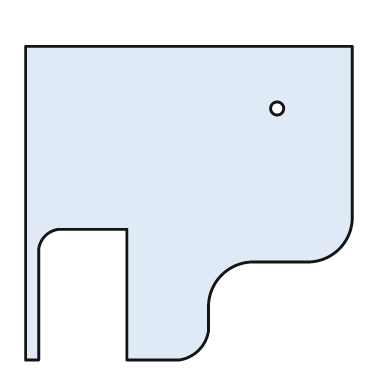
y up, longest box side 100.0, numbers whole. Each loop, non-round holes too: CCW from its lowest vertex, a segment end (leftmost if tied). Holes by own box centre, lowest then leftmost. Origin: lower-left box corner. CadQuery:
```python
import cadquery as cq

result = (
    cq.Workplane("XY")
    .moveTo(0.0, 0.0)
    .lineTo(4.0, 0.0)
    .lineTo(4.0, 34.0)
    .threePointArc((6.0, 38.0), (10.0, 40.0))
    .lineTo(31.0, 40.0)
    .lineTo(31.0, 0.0)
    .lineTo(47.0, 0.0)
    .threePointArc((53.0, 3.0), (56.0, 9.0))
    .lineTo(56.0, 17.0)
    .threePointArc((60.0, 26.0), (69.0, 30.0))
    .lineTo(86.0, 30.0)
    .threePointArc((96.0, 34.0), (100.0, 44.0))
    .lineTo(100.0, 96.0)
    .lineTo(0.0, 96.0)
    .close()
    .moveTo(77.0, 77.0)
    .circle(2.0)
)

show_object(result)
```